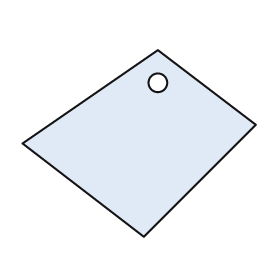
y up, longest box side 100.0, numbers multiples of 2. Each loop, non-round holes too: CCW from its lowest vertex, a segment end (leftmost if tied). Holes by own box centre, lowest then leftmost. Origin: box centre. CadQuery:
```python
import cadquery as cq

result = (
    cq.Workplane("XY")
    .moveTo(2.0, -40.0)
    .lineTo(50.0, 8.0)
    .lineTo(8.0, 40.0)
    .lineTo(-50.0, 0.0)
    .close()
    .moveTo(8.0, 26.0)
    .circle(4.0)
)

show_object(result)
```